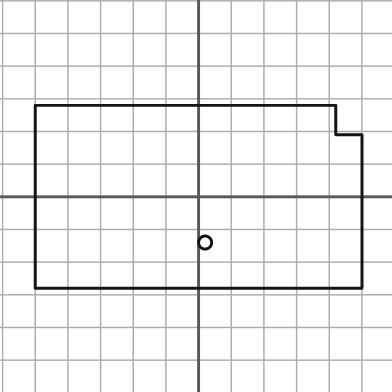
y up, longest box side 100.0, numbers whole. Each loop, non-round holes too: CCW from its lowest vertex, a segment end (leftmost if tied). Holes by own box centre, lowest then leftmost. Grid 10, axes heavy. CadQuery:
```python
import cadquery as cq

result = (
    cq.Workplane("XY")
    .moveTo(-50.0, -28.0)
    .lineTo(50.0, -28.0)
    .lineTo(50.0, 19.0)
    .lineTo(42.0, 19.0)
    .lineTo(42.0, 28.0)
    .lineTo(-50.0, 28.0)
    .close()
    .moveTo(2.0, -14.0)
    .circle(2.0)
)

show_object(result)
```